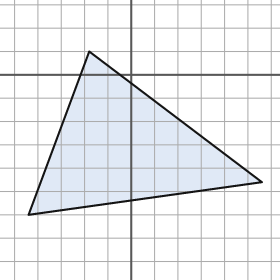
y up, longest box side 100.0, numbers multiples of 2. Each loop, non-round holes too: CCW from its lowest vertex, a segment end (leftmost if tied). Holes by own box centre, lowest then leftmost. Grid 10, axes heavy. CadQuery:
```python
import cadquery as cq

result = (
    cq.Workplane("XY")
    .moveTo(-44.0, -60.0)
    .lineTo(56.0, -46.0)
    .lineTo(-18.0, 10.0)
    .close()
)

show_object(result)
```